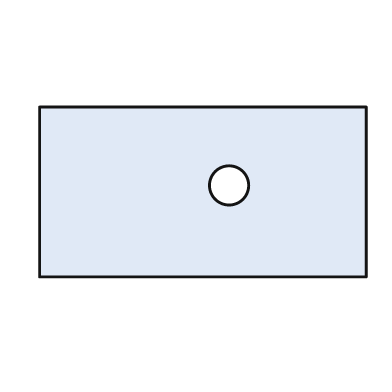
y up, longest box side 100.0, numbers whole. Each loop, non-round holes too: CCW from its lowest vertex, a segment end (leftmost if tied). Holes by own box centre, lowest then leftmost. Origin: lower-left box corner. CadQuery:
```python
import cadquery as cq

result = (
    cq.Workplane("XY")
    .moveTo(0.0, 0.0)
    .lineTo(100.0, 0.0)
    .lineTo(100.0, 52.0)
    .lineTo(0.0, 52.0)
    .close()
    .moveTo(58.0, 28.0)
    .circle(6.0)
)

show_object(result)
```